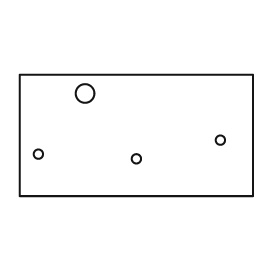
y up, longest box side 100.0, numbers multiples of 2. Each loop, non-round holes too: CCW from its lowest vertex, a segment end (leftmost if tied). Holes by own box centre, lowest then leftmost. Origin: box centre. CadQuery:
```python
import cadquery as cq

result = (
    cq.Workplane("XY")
    .moveTo(-50.0, -26.0)
    .lineTo(50.0, -26.0)
    .lineTo(50.0, 26.0)
    .lineTo(-50.0, 26.0)
    .close()
    .moveTo(0.0, -10.0)
    .circle(2.0)
    .moveTo(-42.0, -8.0)
    .circle(2.0)
    .moveTo(36.0, -2.0)
    .circle(2.0)
    .moveTo(-22.0, 18.0)
    .circle(4.0)
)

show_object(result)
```